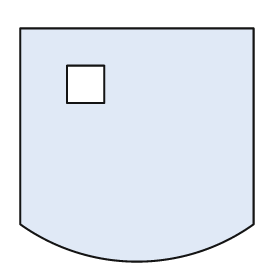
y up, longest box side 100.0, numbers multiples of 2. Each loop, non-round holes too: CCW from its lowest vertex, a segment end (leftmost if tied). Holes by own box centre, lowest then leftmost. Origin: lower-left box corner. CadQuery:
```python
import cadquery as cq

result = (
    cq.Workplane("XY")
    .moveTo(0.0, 16.0)
    .threePointArc((50.0, 0.0), (100.0, 16.0))
    .lineTo(100.0, 100.0)
    .lineTo(0.0, 100.0)
    .close()
    .moveTo(20.0, 68.0)
    .lineTo(36.0, 68.0)
    .lineTo(36.0, 84.0)
    .lineTo(20.0, 84.0)
    .close()
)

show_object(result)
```